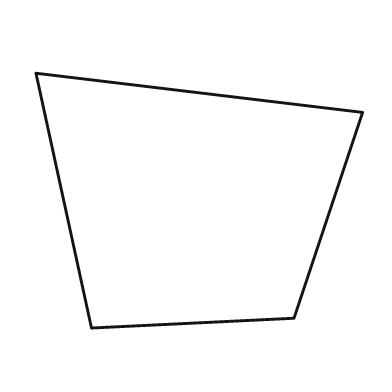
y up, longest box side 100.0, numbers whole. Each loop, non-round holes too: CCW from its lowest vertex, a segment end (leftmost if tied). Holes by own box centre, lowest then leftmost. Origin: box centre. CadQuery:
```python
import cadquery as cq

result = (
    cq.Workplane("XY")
    .moveTo(-33.0, -39.0)
    .lineTo(29.0, -36.0)
    .lineTo(50.0, 27.0)
    .lineTo(-50.0, 39.0)
    .close()
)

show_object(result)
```